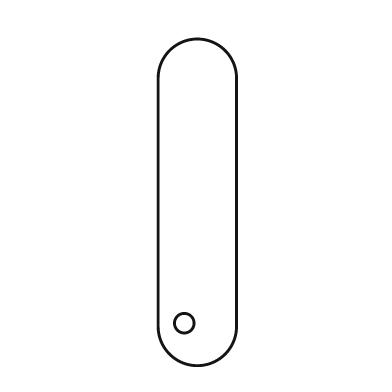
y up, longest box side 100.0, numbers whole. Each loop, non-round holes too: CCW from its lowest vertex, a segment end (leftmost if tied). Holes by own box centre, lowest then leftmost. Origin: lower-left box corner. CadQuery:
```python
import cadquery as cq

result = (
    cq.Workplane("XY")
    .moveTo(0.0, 12.0)
    .threePointArc((12.0, 0.0), (24.0, 12.0))
    .lineTo(24.0, 88.0)
    .threePointArc((12.0, 100.0), (0.0, 88.0))
    .close()
    .moveTo(8.0, 13.0)
    .circle(3.0)
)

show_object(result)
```